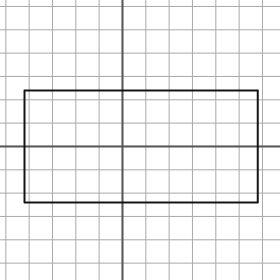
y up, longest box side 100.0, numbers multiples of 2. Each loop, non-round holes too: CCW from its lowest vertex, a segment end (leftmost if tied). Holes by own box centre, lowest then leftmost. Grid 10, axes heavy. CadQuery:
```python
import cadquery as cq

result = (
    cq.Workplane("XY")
    .moveTo(-42.0, -24.0)
    .lineTo(58.0, -24.0)
    .lineTo(58.0, 24.0)
    .lineTo(-42.0, 24.0)
    .close()
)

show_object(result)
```